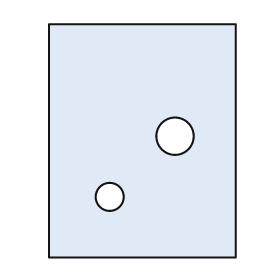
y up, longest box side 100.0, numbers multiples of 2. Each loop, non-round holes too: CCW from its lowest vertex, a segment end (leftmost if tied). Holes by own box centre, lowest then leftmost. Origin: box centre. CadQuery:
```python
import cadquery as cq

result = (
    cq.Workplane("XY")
    .moveTo(-40.0, -50.0)
    .lineTo(40.0, -50.0)
    .lineTo(40.0, 50.0)
    .lineTo(-40.0, 50.0)
    .close()
    .moveTo(-14.0, -24.0)
    .circle(6.0)
    .moveTo(14.0, 2.0)
    .circle(8.0)
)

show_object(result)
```